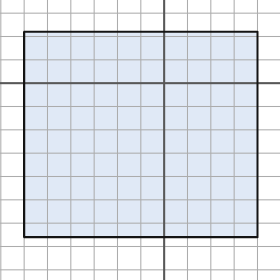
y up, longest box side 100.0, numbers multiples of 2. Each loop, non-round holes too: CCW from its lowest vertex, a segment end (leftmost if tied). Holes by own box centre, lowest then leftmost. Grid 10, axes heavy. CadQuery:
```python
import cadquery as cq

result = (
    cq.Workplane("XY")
    .moveTo(-60.0, -66.0)
    .lineTo(40.0, -66.0)
    .lineTo(40.0, 22.0)
    .lineTo(-60.0, 22.0)
    .close()
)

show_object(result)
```